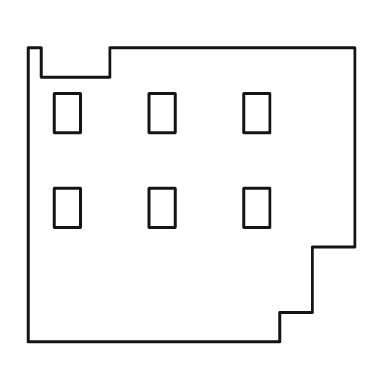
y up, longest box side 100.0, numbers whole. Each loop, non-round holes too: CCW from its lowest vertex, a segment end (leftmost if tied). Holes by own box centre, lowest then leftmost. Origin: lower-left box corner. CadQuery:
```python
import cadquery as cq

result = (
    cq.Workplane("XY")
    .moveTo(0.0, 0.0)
    .lineTo(77.0, 0.0)
    .lineTo(77.0, 9.0)
    .lineTo(87.0, 9.0)
    .lineTo(87.0, 29.0)
    .lineTo(100.0, 29.0)
    .lineTo(100.0, 90.0)
    .lineTo(25.0, 90.0)
    .lineTo(25.0, 81.0)
    .lineTo(4.0, 81.0)
    .lineTo(4.0, 90.0)
    .lineTo(0.0, 90.0)
    .close()
    .moveTo(8.0, 35.0)
    .lineTo(16.0, 35.0)
    .lineTo(16.0, 47.0)
    .lineTo(8.0, 47.0)
    .close()
    .moveTo(37.0, 35.0)
    .lineTo(45.0, 35.0)
    .lineTo(45.0, 47.0)
    .lineTo(37.0, 47.0)
    .close()
    .moveTo(66.0, 35.0)
    .lineTo(74.0, 35.0)
    .lineTo(74.0, 47.0)
    .lineTo(66.0, 47.0)
    .close()
    .moveTo(8.0, 64.0)
    .lineTo(16.0, 64.0)
    .lineTo(16.0, 76.0)
    .lineTo(8.0, 76.0)
    .close()
    .moveTo(37.0, 64.0)
    .lineTo(45.0, 64.0)
    .lineTo(45.0, 76.0)
    .lineTo(37.0, 76.0)
    .close()
    .moveTo(66.0, 64.0)
    .lineTo(74.0, 64.0)
    .lineTo(74.0, 76.0)
    .lineTo(66.0, 76.0)
    .close()
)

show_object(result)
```